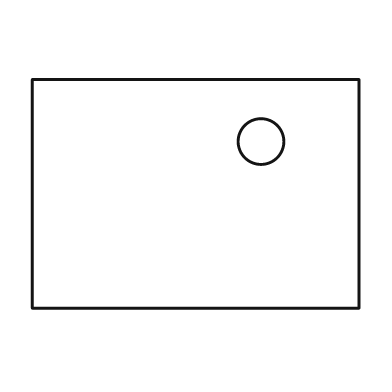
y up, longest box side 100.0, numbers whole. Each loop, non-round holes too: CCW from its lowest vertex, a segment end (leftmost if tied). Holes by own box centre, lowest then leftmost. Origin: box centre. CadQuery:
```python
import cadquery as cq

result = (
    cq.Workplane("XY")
    .moveTo(-50.0, -35.0)
    .lineTo(50.0, -35.0)
    .lineTo(50.0, 35.0)
    .lineTo(-50.0, 35.0)
    .close()
    .moveTo(20.0, 16.0)
    .circle(7.0)
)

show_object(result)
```